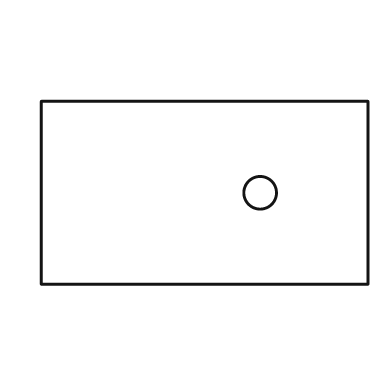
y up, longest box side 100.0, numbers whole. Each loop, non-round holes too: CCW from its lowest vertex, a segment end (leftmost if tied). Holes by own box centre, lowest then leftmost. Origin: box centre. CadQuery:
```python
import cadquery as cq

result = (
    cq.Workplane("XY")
    .moveTo(-50.0, -28.0)
    .lineTo(50.0, -28.0)
    .lineTo(50.0, 28.0)
    .lineTo(-50.0, 28.0)
    .close()
    .moveTo(17.0, 0.0)
    .circle(5.0)
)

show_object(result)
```